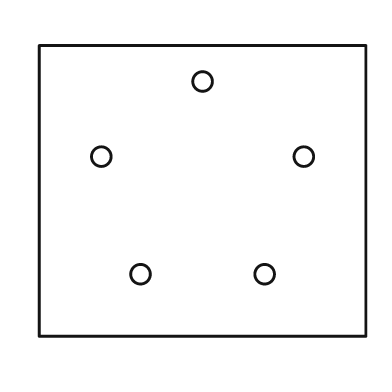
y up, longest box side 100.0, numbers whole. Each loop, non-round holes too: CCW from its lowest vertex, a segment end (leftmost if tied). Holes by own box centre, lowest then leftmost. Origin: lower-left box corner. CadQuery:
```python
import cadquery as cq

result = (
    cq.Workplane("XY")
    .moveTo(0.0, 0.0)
    .lineTo(100.0, 0.0)
    .lineTo(100.0, 89.0)
    .lineTo(0.0, 89.0)
    .close()
    .moveTo(31.0, 19.0)
    .circle(3.0)
    .moveTo(69.0, 19.0)
    .circle(3.0)
    .moveTo(19.0, 55.0)
    .circle(3.0)
    .moveTo(81.0, 55.0)
    .circle(3.0)
    .moveTo(50.0, 78.0)
    .circle(3.0)
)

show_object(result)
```